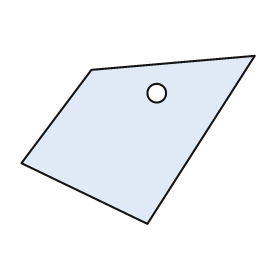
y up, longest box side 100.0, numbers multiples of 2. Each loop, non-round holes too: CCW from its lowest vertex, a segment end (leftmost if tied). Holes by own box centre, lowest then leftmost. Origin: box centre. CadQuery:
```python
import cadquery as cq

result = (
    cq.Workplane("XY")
    .moveTo(4.0, -36.0)
    .lineTo(50.0, 36.0)
    .lineTo(-20.0, 30.0)
    .lineTo(-50.0, -10.0)
    .close()
    .moveTo(8.0, 20.0)
    .circle(4.0)
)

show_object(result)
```